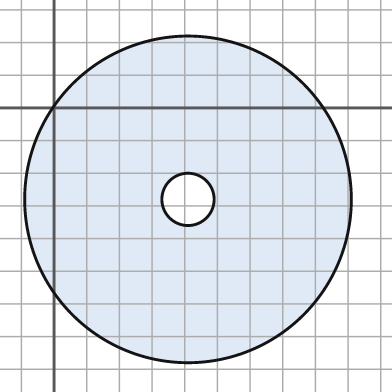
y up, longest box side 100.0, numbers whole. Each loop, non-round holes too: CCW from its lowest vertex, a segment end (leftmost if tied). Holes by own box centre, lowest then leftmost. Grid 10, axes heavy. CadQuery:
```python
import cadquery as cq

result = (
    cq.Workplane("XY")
    .moveTo(41.0, -28.0)
    .circle(50.0)
    .moveTo(41.0, -28.0)
    .circle(8.0)
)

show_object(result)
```